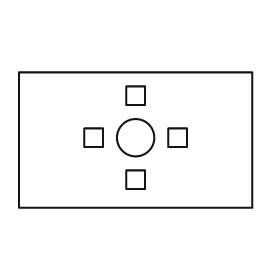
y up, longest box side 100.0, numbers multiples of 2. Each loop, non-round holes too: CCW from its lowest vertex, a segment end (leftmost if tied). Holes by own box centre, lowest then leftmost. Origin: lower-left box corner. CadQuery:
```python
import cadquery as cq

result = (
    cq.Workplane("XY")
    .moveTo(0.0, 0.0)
    .lineTo(100.0, 0.0)
    .lineTo(100.0, 58.0)
    .lineTo(0.0, 58.0)
    .close()
    .moveTo(46.0, 8.0)
    .lineTo(54.0, 8.0)
    .lineTo(54.0, 16.0)
    .lineTo(46.0, 16.0)
    .close()
    .moveTo(28.0, 26.0)
    .lineTo(36.0, 26.0)
    .lineTo(36.0, 34.0)
    .lineTo(28.0, 34.0)
    .close()
    .moveTo(50.0, 30.0)
    .circle(8.0)
    .moveTo(64.0, 26.0)
    .lineTo(72.0, 26.0)
    .lineTo(72.0, 34.0)
    .lineTo(64.0, 34.0)
    .close()
    .moveTo(46.0, 44.0)
    .lineTo(54.0, 44.0)
    .lineTo(54.0, 52.0)
    .lineTo(46.0, 52.0)
    .close()
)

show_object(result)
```